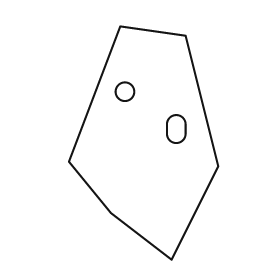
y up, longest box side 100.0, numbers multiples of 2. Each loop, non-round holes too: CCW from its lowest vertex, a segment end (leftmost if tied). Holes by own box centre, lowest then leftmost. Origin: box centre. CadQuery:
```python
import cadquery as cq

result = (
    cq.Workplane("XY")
    .moveTo(12.0, -50.0)
    .lineTo(32.0, -10.0)
    .lineTo(18.0, 46.0)
    .lineTo(-10.0, 50.0)
    .lineTo(-32.0, -8.0)
    .lineTo(-14.0, -30.0)
    .close()
    .moveTo(10.0, 4.0)
    .threePointArc((14.0, 0.0), (18.0, 4.0))
    .lineTo(18.0, 8.0)
    .threePointArc((14.0, 12.0), (10.0, 8.0))
    .close()
    .moveTo(-8.0, 22.0)
    .circle(4.0)
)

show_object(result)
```